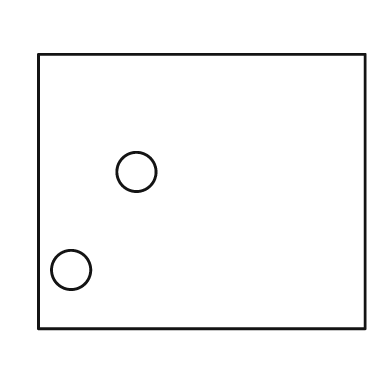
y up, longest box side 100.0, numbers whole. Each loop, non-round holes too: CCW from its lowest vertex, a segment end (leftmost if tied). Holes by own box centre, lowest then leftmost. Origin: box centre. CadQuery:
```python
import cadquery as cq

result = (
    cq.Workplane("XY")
    .moveTo(-50.0, -42.0)
    .lineTo(50.0, -42.0)
    .lineTo(50.0, 42.0)
    .lineTo(-50.0, 42.0)
    .close()
    .moveTo(-40.0, -24.0)
    .circle(6.0)
    .moveTo(-20.0, 6.0)
    .circle(6.0)
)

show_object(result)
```